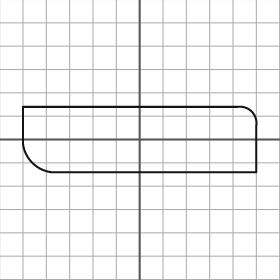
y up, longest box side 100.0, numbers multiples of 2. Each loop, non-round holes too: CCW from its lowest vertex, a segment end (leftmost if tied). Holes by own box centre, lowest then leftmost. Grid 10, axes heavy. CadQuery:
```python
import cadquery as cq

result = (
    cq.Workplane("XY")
    .moveTo(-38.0, -14.0)
    .lineTo(50.0, -14.0)
    .lineTo(50.0, 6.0)
    .threePointArc((48.0, 12.0), (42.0, 14.0))
    .lineTo(-50.0, 14.0)
    .lineTo(-50.0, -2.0)
    .threePointArc((-46.0, -10.0), (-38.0, -14.0))
    .close()
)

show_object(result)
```